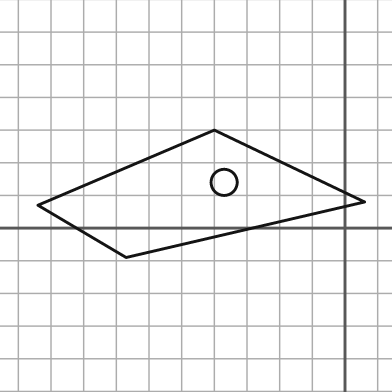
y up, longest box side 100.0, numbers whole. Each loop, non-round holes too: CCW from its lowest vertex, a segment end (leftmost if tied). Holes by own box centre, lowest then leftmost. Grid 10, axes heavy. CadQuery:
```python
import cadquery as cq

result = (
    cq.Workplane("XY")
    .moveTo(-67.0, -9.0)
    .lineTo(6.0, 8.0)
    .lineTo(-40.0, 30.0)
    .lineTo(-94.0, 7.0)
    .close()
    .moveTo(-37.0, 14.0)
    .circle(4.0)
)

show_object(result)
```